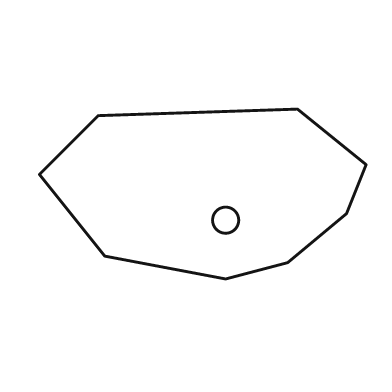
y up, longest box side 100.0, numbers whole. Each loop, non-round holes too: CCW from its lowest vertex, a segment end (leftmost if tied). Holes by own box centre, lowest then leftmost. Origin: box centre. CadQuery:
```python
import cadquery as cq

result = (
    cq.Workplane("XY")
    .moveTo(7.0, -26.0)
    .lineTo(26.0, -21.0)
    .lineTo(44.0, -6.0)
    .lineTo(50.0, 9.0)
    .lineTo(29.0, 26.0)
    .lineTo(-32.0, 24.0)
    .lineTo(-50.0, 6.0)
    .lineTo(-30.0, -19.0)
    .close()
    .moveTo(7.0, -8.0)
    .circle(4.0)
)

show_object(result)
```